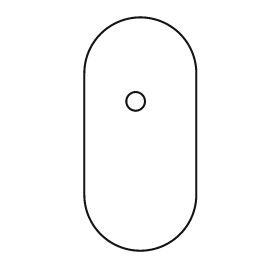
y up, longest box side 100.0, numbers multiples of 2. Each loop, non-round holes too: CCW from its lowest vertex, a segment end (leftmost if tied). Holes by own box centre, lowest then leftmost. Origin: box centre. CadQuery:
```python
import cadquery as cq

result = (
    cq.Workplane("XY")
    .moveTo(-24.0, -26.0)
    .threePointArc((0.0, -50.0), (24.0, -26.0))
    .lineTo(24.0, 26.0)
    .threePointArc((0.0, 50.0), (-24.0, 26.0))
    .close()
    .moveTo(-2.0, 14.0)
    .circle(4.0)
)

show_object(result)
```